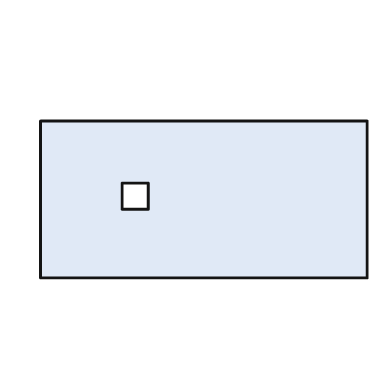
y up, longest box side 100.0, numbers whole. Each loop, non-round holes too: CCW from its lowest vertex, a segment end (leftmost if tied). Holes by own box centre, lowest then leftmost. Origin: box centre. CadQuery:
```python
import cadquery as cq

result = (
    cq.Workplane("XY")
    .moveTo(-50.0, -24.0)
    .lineTo(50.0, -24.0)
    .lineTo(50.0, 24.0)
    .lineTo(-50.0, 24.0)
    .close()
    .moveTo(-25.0, -3.0)
    .lineTo(-17.0, -3.0)
    .lineTo(-17.0, 5.0)
    .lineTo(-25.0, 5.0)
    .close()
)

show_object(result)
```